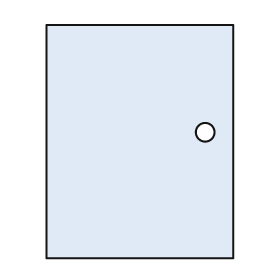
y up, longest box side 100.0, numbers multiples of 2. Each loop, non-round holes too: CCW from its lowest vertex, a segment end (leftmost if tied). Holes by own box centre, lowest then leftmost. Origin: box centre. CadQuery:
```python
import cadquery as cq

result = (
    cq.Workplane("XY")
    .moveTo(-40.0, -50.0)
    .lineTo(40.0, -50.0)
    .lineTo(40.0, 50.0)
    .lineTo(-40.0, 50.0)
    .close()
    .moveTo(28.0, 4.0)
    .circle(4.0)
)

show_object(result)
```